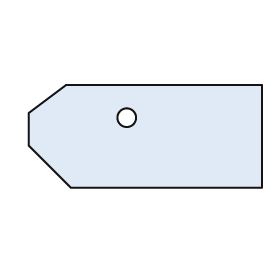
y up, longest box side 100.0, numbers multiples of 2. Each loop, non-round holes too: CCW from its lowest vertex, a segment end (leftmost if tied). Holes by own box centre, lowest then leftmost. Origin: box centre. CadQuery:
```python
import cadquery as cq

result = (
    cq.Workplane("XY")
    .moveTo(-32.0, -22.0)
    .lineTo(50.0, -22.0)
    .lineTo(50.0, 22.0)
    .lineTo(-34.0, 22.0)
    .lineTo(-50.0, 10.0)
    .lineTo(-50.0, -4.0)
    .close()
    .moveTo(-8.0, 8.0)
    .circle(4.0)
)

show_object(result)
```